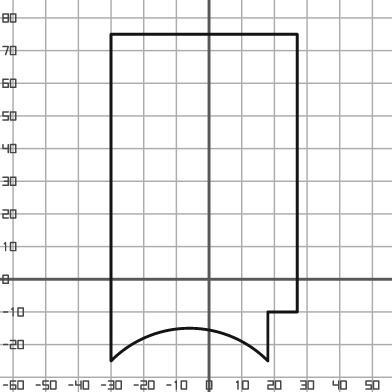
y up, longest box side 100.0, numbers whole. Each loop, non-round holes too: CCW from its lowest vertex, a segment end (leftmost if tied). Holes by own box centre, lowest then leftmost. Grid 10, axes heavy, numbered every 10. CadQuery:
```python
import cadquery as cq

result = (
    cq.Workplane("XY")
    .moveTo(-30.0, -25.0)
    .threePointArc((-6.0, -15.0), (18.0, -25.0))
    .lineTo(18.0, -10.0)
    .lineTo(27.0, -10.0)
    .lineTo(27.0, 75.0)
    .lineTo(-30.0, 75.0)
    .close()
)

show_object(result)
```